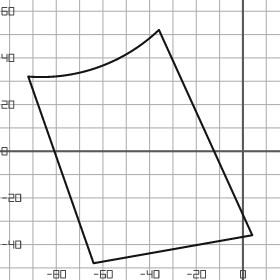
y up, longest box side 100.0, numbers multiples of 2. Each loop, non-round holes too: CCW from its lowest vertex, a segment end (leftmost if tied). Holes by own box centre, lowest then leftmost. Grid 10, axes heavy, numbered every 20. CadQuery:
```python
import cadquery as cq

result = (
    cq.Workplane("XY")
    .moveTo(-64.0, -48.0)
    .lineTo(4.0, -36.0)
    .lineTo(-36.0, 52.0)
    .threePointArc((-62.0, 36.0), (-92.0, 32.0))
    .close()
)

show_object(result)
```